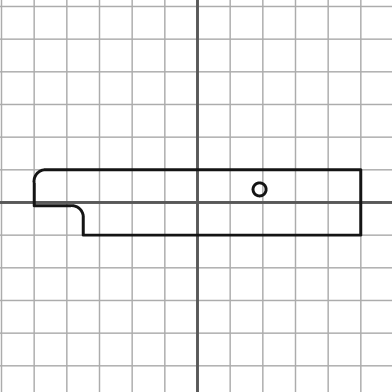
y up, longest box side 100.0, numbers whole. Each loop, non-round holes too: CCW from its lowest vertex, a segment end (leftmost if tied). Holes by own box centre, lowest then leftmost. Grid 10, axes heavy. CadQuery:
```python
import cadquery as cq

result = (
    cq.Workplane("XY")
    .moveTo(-35.0, -10.0)
    .lineTo(50.0, -10.0)
    .lineTo(50.0, 10.0)
    .lineTo(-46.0, 10.0)
    .threePointArc((-49.0, 9.0), (-50.0, 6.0))
    .lineTo(-50.0, -1.0)
    .lineTo(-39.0, -1.0)
    .threePointArc((-36.0, -2.0), (-35.0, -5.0))
    .close()
    .moveTo(19.0, 4.0)
    .circle(2.0)
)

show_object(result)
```